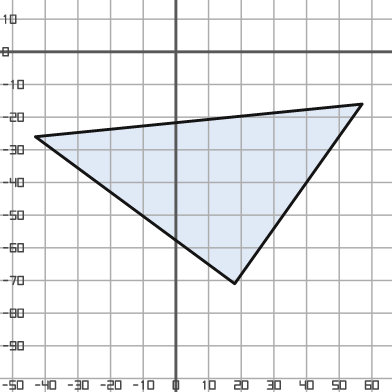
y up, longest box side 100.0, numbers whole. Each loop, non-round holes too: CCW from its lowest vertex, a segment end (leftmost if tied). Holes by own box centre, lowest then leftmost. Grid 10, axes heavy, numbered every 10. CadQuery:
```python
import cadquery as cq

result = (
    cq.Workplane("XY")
    .moveTo(18.0, -71.0)
    .lineTo(57.0, -16.0)
    .lineTo(-43.0, -26.0)
    .close()
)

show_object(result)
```